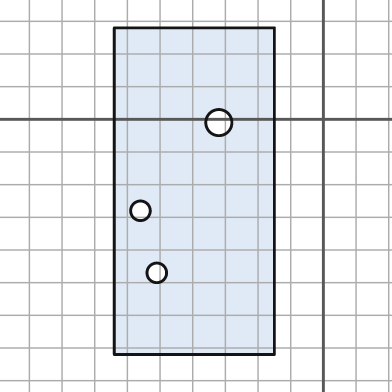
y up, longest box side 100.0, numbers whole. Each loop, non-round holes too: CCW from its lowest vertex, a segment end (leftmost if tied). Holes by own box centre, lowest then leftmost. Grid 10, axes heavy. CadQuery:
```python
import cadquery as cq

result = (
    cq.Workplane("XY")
    .moveTo(-64.0, -72.0)
    .lineTo(-15.0, -72.0)
    .lineTo(-15.0, 28.0)
    .lineTo(-64.0, 28.0)
    .close()
    .moveTo(-51.0, -47.0)
    .circle(3.0)
    .moveTo(-56.0, -28.0)
    .circle(3.0)
    .moveTo(-32.0, -1.0)
    .circle(4.0)
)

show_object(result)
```